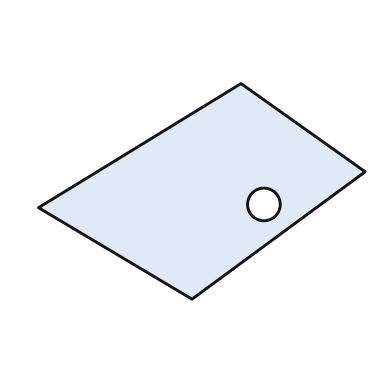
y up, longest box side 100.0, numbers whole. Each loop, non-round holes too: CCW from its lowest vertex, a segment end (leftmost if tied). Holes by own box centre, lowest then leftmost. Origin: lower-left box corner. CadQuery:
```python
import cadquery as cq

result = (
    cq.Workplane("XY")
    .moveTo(47.0, 0.0)
    .lineTo(100.0, 39.0)
    .lineTo(62.0, 66.0)
    .lineTo(0.0, 28.0)
    .close()
    .moveTo(69.0, 29.0)
    .circle(5.0)
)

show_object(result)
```